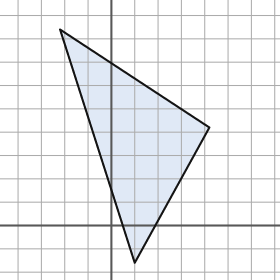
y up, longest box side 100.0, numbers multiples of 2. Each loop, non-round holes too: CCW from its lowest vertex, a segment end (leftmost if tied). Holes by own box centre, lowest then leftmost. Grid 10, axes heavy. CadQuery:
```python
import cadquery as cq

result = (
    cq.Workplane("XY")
    .moveTo(10.0, -16.0)
    .lineTo(42.0, 42.0)
    .lineTo(-22.0, 84.0)
    .close()
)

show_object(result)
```